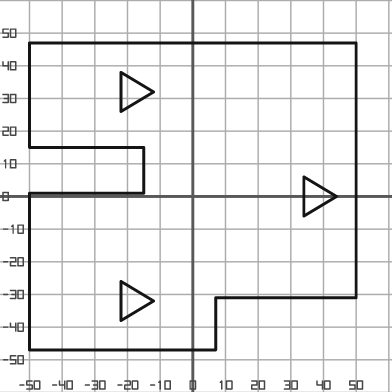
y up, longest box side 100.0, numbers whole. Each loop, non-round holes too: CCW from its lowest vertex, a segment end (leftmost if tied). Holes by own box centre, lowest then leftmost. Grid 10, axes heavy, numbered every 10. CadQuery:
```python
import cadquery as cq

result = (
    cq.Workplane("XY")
    .moveTo(-50.0, -47.0)
    .lineTo(7.0, -47.0)
    .lineTo(7.0, -31.0)
    .lineTo(50.0, -31.0)
    .lineTo(50.0, 47.0)
    .lineTo(-50.0, 47.0)
    .lineTo(-50.0, 15.0)
    .lineTo(-15.0, 15.0)
    .lineTo(-15.0, 1.0)
    .lineTo(-50.0, 1.0)
    .close()
    .moveTo(-22.0, -38.0)
    .lineTo(-12.0, -32.0)
    .lineTo(-22.0, -26.0)
    .close()
    .moveTo(34.0, -6.0)
    .lineTo(44.0, 0.0)
    .lineTo(34.0, 6.0)
    .close()
    .moveTo(-22.0, 26.0)
    .lineTo(-12.0, 32.0)
    .lineTo(-22.0, 38.0)
    .close()
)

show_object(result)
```